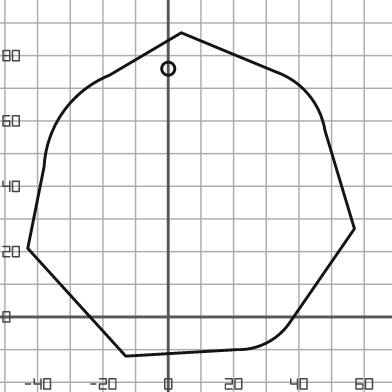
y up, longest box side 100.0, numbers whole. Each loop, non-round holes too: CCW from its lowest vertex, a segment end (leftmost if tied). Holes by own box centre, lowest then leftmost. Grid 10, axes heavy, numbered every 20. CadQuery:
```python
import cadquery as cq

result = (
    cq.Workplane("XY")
    .moveTo(-13.0, -12.0)
    .lineTo(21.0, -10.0)
    .threePointArc((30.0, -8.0), (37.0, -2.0))
    .lineTo(57.0, 27.0)
    .lineTo(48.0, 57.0)
    .threePointArc((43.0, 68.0), (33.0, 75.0))
    .lineTo(4.0, 87.0)
    .lineTo(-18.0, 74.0)
    .threePointArc((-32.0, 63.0), (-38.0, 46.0))
    .lineTo(-43.0, 21.0)
    .close()
    .moveTo(0.0, 76.0)
    .circle(2.0)
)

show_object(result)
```